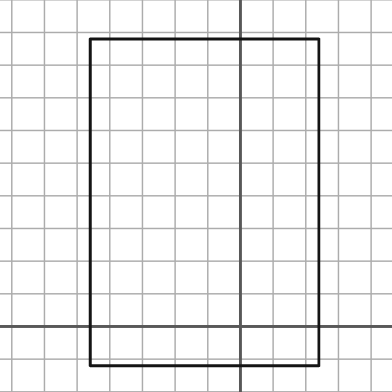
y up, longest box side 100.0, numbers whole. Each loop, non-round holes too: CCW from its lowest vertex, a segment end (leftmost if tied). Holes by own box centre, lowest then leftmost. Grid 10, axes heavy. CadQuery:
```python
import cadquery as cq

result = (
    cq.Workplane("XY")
    .moveTo(-46.0, -12.0)
    .lineTo(24.0, -12.0)
    .lineTo(24.0, 88.0)
    .lineTo(-46.0, 88.0)
    .close()
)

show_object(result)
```